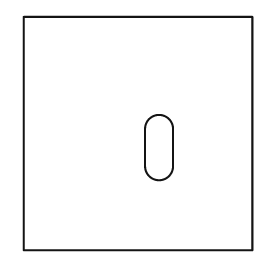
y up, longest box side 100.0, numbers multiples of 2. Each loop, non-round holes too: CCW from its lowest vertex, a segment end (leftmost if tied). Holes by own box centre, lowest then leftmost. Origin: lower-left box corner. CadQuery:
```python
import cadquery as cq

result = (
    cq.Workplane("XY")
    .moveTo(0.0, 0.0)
    .lineTo(98.0, 0.0)
    .lineTo(98.0, 100.0)
    .lineTo(0.0, 100.0)
    .close()
    .moveTo(52.0, 36.0)
    .threePointArc((58.0, 30.0), (64.0, 36.0))
    .lineTo(64.0, 52.0)
    .threePointArc((58.0, 58.0), (52.0, 52.0))
    .close()
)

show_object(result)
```